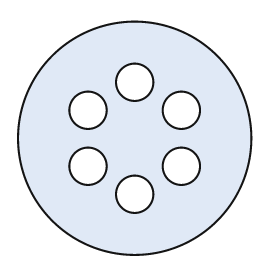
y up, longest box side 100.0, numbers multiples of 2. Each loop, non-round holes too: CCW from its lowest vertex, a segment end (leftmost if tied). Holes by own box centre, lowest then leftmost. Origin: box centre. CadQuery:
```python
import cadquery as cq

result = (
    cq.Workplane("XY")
    .moveTo(0.0, 0.0)
    .circle(50.0)
    .moveTo(0.0, -24.0)
    .circle(8.0)
    .moveTo(-20.0, -12.0)
    .circle(8.0)
    .moveTo(20.0, -12.0)
    .circle(8.0)
    .moveTo(-20.0, 12.0)
    .circle(8.0)
    .moveTo(20.0, 12.0)
    .circle(8.0)
    .moveTo(0.0, 24.0)
    .circle(8.0)
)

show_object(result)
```